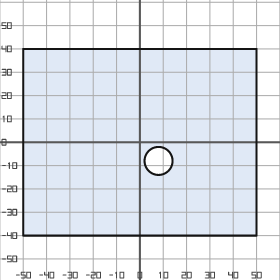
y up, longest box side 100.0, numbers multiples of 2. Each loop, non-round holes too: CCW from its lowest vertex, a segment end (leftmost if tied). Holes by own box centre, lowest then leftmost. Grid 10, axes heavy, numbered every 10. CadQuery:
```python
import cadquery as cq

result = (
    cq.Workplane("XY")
    .moveTo(-50.0, -40.0)
    .lineTo(50.0, -40.0)
    .lineTo(50.0, 40.0)
    .lineTo(-50.0, 40.0)
    .close()
    .moveTo(8.0, -8.0)
    .circle(6.0)
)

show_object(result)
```